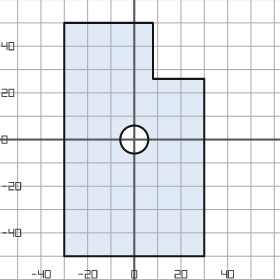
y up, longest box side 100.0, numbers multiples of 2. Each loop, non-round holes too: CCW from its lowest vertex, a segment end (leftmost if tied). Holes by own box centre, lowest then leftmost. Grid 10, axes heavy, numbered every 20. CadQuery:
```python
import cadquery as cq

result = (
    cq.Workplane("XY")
    .moveTo(-30.0, -50.0)
    .lineTo(30.0, -50.0)
    .lineTo(30.0, 26.0)
    .lineTo(8.0, 26.0)
    .lineTo(8.0, 50.0)
    .lineTo(-30.0, 50.0)
    .close()
    .moveTo(0.0, 0.0)
    .circle(6.0)
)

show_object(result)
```